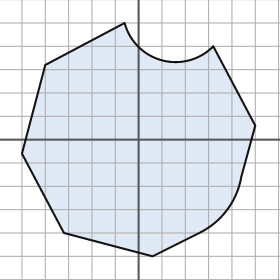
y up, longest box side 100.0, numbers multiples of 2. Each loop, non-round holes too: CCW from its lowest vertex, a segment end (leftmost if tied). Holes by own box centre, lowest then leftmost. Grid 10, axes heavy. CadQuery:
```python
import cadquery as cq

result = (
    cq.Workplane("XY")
    .moveTo(6.0, -50.0)
    .lineTo(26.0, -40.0)
    .threePointArc((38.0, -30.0), (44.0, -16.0))
    .lineTo(50.0, 6.0)
    .lineTo(32.0, 40.0)
    .threePointArc((10.0, 34.0), (-6.0, 50.0))
    .lineTo(-40.0, 32.0)
    .lineTo(-50.0, -6.0)
    .lineTo(-32.0, -40.0)
    .close()
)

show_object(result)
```